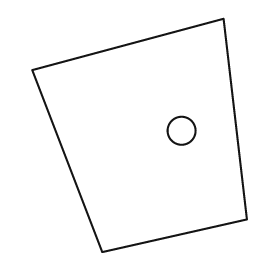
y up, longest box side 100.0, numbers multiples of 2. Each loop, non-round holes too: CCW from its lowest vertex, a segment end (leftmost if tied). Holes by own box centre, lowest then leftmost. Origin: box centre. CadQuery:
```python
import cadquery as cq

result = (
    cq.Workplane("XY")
    .moveTo(-16.0, -50.0)
    .lineTo(46.0, -36.0)
    .lineTo(36.0, 50.0)
    .lineTo(-46.0, 28.0)
    .close()
    .moveTo(18.0, 2.0)
    .circle(6.0)
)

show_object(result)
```